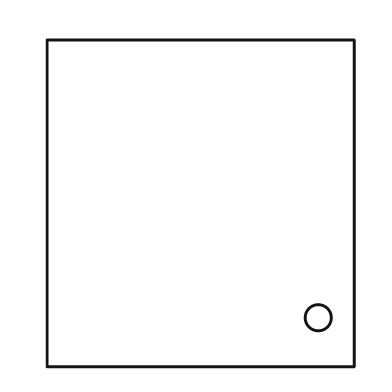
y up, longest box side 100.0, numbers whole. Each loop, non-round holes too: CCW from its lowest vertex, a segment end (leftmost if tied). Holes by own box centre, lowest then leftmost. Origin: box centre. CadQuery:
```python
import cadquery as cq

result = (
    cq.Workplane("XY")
    .moveTo(-47.0, -50.0)
    .lineTo(47.0, -50.0)
    .lineTo(47.0, 50.0)
    .lineTo(-47.0, 50.0)
    .close()
    .moveTo(36.0, -35.0)
    .circle(4.0)
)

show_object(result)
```